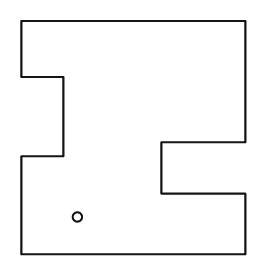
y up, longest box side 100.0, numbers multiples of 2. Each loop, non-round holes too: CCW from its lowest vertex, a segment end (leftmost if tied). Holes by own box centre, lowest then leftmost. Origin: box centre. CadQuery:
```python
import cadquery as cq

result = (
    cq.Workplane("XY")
    .moveTo(-48.0, -50.0)
    .lineTo(48.0, -50.0)
    .lineTo(48.0, -24.0)
    .lineTo(12.0, -24.0)
    .lineTo(12.0, -2.0)
    .lineTo(48.0, -2.0)
    .lineTo(48.0, 50.0)
    .lineTo(-48.0, 50.0)
    .lineTo(-48.0, 26.0)
    .lineTo(-30.0, 26.0)
    .lineTo(-30.0, -8.0)
    .lineTo(-48.0, -8.0)
    .close()
    .moveTo(-24.0, -34.0)
    .circle(2.0)
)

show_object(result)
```